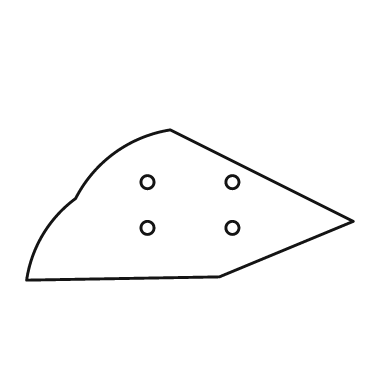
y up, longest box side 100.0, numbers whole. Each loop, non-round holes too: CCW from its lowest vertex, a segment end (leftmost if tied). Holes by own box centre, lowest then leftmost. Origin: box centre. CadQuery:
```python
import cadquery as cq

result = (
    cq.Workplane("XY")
    .moveTo(-50.0, -23.0)
    .lineTo(9.0, -22.0)
    .lineTo(50.0, -5.0)
    .lineTo(-6.0, 23.0)
    .threePointArc((-23.0, 16.0), (-35.0, 2.0))
    .threePointArc((-45.0, -9.0), (-50.0, -23.0))
    .close()
    .moveTo(-13.0, -7.0)
    .circle(2.0)
    .moveTo(13.0, -7.0)
    .circle(2.0)
    .moveTo(-13.0, 7.0)
    .circle(2.0)
    .moveTo(13.0, 7.0)
    .circle(2.0)
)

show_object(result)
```